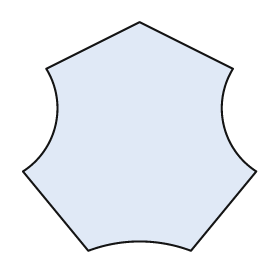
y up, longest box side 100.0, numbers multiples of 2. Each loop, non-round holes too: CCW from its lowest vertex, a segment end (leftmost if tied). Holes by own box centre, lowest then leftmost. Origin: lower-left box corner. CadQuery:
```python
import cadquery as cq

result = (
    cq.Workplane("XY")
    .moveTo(28.0, 0.0)
    .threePointArc((50.0, 4.0), (72.0, 0.0))
    .lineTo(100.0, 34.0)
    .threePointArc((86.0, 54.0), (90.0, 78.0))
    .lineTo(50.0, 98.0)
    .lineTo(10.0, 78.0)
    .threePointArc((14.0, 54.0), (0.0, 34.0))
    .close()
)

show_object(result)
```